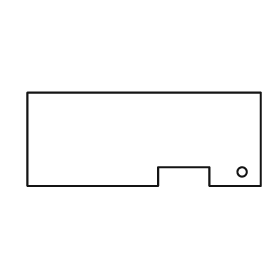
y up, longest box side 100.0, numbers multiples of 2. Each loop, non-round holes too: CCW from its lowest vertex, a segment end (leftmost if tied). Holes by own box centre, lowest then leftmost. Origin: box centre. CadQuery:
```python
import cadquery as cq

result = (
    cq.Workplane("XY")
    .moveTo(-50.0, -20.0)
    .lineTo(6.0, -20.0)
    .lineTo(6.0, -12.0)
    .lineTo(28.0, -12.0)
    .lineTo(28.0, -20.0)
    .lineTo(50.0, -20.0)
    .lineTo(50.0, 20.0)
    .lineTo(-50.0, 20.0)
    .close()
    .moveTo(42.0, -14.0)
    .circle(2.0)
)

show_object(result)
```